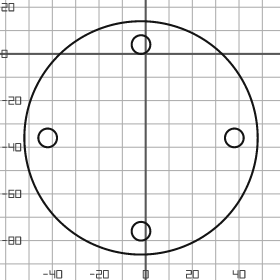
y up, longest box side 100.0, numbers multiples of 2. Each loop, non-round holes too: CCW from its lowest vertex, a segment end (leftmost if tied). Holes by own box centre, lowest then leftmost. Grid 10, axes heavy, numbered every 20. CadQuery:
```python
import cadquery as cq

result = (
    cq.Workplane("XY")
    .moveTo(-2.0, -36.0)
    .circle(50.0)
    .moveTo(-2.0, -76.0)
    .circle(4.0)
    .moveTo(-42.0, -36.0)
    .circle(4.0)
    .moveTo(38.0, -36.0)
    .circle(4.0)
    .moveTo(-2.0, 4.0)
    .circle(4.0)
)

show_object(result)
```